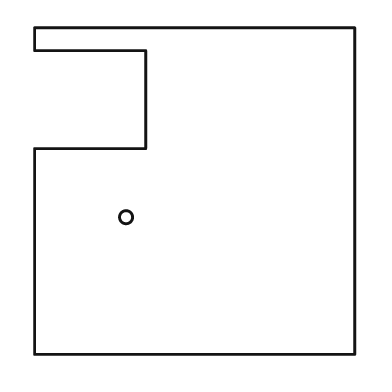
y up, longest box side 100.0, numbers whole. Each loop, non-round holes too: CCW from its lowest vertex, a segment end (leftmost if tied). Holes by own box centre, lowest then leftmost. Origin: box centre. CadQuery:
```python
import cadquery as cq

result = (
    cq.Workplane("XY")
    .moveTo(-49.0, -50.0)
    .lineTo(49.0, -50.0)
    .lineTo(49.0, 50.0)
    .lineTo(-49.0, 50.0)
    .lineTo(-49.0, 43.0)
    .lineTo(-15.0, 43.0)
    .lineTo(-15.0, 13.0)
    .lineTo(-49.0, 13.0)
    .close()
    .moveTo(-21.0, -8.0)
    .circle(2.0)
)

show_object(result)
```